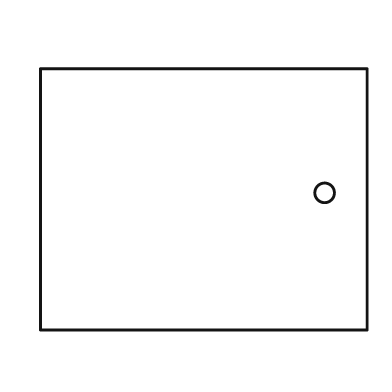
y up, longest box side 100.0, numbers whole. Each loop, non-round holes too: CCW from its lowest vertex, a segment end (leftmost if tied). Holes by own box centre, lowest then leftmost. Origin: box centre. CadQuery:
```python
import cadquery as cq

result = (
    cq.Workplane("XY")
    .moveTo(-50.0, -40.0)
    .lineTo(50.0, -40.0)
    .lineTo(50.0, 40.0)
    .lineTo(-50.0, 40.0)
    .close()
    .moveTo(37.0, 2.0)
    .circle(3.0)
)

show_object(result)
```